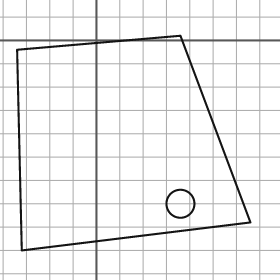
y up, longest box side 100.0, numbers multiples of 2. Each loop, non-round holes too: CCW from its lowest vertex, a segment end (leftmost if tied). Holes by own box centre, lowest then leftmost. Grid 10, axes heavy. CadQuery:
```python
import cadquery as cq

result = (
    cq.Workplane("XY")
    .moveTo(-32.0, -90.0)
    .lineTo(66.0, -78.0)
    .lineTo(36.0, 2.0)
    .lineTo(-34.0, -4.0)
    .close()
    .moveTo(36.0, -70.0)
    .circle(6.0)
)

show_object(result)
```